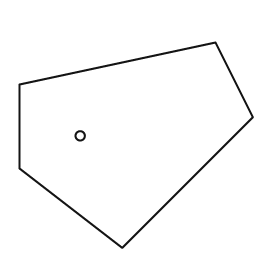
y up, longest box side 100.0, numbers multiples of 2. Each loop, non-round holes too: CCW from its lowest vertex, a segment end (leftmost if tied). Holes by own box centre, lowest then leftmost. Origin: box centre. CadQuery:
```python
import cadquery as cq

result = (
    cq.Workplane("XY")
    .moveTo(-6.0, -44.0)
    .lineTo(50.0, 12.0)
    .lineTo(34.0, 44.0)
    .lineTo(-50.0, 26.0)
    .lineTo(-50.0, -10.0)
    .close()
    .moveTo(-24.0, 4.0)
    .circle(2.0)
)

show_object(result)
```